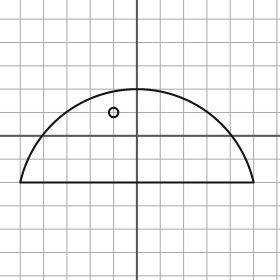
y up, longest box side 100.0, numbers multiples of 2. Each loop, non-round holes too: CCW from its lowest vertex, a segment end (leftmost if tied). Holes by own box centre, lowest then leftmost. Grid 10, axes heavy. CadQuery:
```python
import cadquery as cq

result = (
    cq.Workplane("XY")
    .moveTo(-50.0, -20.0)
    .lineTo(50.0, -20.0)
    .threePointArc((0.0, 20.0), (-50.0, -20.0))
    .close()
    .moveTo(-10.0, 10.0)
    .circle(2.0)
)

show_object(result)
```